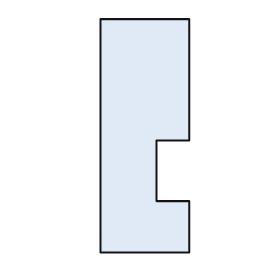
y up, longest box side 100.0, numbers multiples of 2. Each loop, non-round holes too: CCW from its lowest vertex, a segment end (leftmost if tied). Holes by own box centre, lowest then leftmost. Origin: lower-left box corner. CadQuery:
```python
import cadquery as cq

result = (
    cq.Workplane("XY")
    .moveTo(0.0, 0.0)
    .lineTo(38.0, 0.0)
    .lineTo(38.0, 22.0)
    .lineTo(24.0, 22.0)
    .lineTo(24.0, 48.0)
    .lineTo(38.0, 48.0)
    .lineTo(38.0, 100.0)
    .lineTo(0.0, 100.0)
    .close()
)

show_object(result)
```